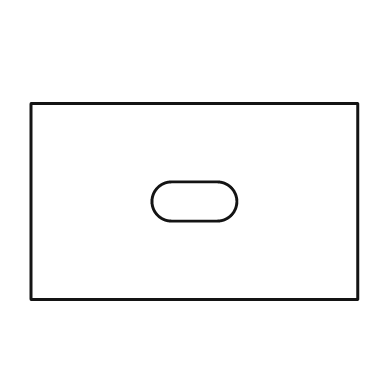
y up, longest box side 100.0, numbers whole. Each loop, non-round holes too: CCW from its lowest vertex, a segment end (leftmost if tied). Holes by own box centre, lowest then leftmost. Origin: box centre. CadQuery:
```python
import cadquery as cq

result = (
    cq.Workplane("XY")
    .moveTo(-50.0, -30.0)
    .lineTo(50.0, -30.0)
    .lineTo(50.0, 30.0)
    .lineTo(-50.0, 30.0)
    .close()
    .moveTo(-7.0, -6.0)
    .lineTo(7.0, -6.0)
    .threePointArc((13.0, 0.0), (7.0, 6.0))
    .lineTo(-7.0, 6.0)
    .threePointArc((-13.0, 0.0), (-7.0, -6.0))
    .close()
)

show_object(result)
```